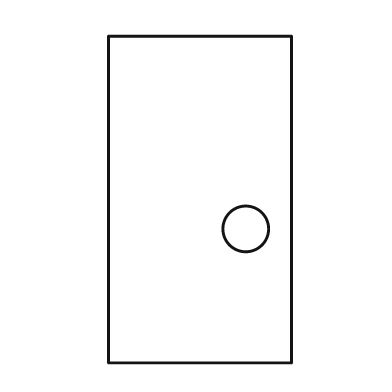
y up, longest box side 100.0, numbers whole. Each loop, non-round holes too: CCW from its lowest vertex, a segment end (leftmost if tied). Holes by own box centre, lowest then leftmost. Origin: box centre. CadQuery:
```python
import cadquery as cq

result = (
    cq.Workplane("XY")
    .moveTo(-28.0, -50.0)
    .lineTo(28.0, -50.0)
    .lineTo(28.0, 50.0)
    .lineTo(-28.0, 50.0)
    .close()
    .moveTo(14.0, -9.0)
    .circle(7.0)
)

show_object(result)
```